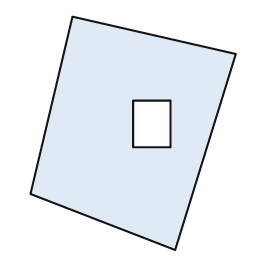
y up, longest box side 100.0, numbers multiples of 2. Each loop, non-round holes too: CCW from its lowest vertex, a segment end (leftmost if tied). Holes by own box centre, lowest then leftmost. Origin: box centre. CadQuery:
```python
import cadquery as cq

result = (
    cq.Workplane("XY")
    .moveTo(18.0, -50.0)
    .lineTo(44.0, 34.0)
    .lineTo(-26.0, 50.0)
    .lineTo(-44.0, -26.0)
    .close()
    .moveTo(0.0, -6.0)
    .lineTo(16.0, -6.0)
    .lineTo(16.0, 14.0)
    .lineTo(0.0, 14.0)
    .close()
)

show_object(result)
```